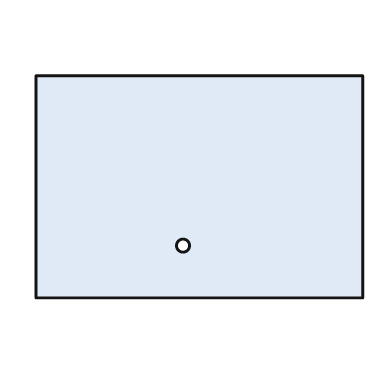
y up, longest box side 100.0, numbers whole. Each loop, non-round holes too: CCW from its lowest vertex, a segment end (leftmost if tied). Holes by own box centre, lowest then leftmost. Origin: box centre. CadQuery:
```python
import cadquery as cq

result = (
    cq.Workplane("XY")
    .moveTo(-50.0, -34.0)
    .lineTo(50.0, -34.0)
    .lineTo(50.0, 34.0)
    .lineTo(-50.0, 34.0)
    .close()
    .moveTo(-5.0, -18.0)
    .circle(2.0)
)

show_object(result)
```